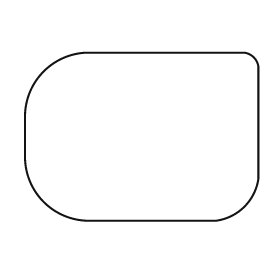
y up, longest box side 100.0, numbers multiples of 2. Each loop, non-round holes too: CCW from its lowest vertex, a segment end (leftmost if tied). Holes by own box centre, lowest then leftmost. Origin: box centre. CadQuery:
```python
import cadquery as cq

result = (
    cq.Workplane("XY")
    .moveTo(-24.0, -36.0)
    .lineTo(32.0, -36.0)
    .threePointArc((44.0, -30.0), (50.0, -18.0))
    .lineTo(50.0, 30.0)
    .threePointArc((48.0, 34.0), (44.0, 36.0))
    .lineTo(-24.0, 36.0)
    .threePointArc((-42.0, 28.0), (-50.0, 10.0))
    .lineTo(-50.0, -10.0)
    .threePointArc((-42.0, -28.0), (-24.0, -36.0))
    .close()
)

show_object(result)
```